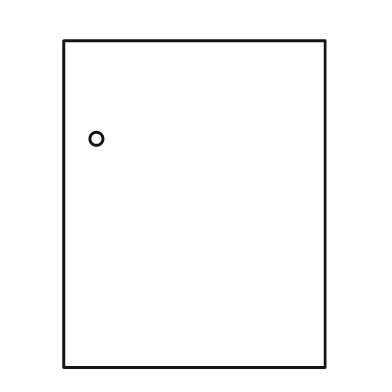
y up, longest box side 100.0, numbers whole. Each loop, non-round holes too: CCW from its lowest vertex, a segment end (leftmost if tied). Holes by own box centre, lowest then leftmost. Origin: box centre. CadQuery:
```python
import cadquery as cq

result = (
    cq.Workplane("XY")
    .moveTo(-40.0, -50.0)
    .lineTo(40.0, -50.0)
    .lineTo(40.0, 50.0)
    .lineTo(-40.0, 50.0)
    .close()
    .moveTo(-30.0, 20.0)
    .circle(2.0)
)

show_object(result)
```